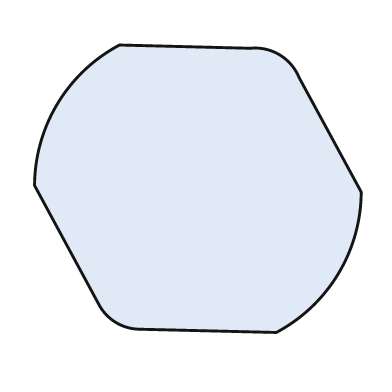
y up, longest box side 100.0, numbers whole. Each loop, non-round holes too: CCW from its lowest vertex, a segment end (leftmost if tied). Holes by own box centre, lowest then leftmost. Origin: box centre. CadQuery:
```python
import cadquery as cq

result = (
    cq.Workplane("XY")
    .moveTo(24.0, -44.0)
    .threePointArc((43.0, -26.0), (50.0, -1.0))
    .lineTo(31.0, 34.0)
    .threePointArc((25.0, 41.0), (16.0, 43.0))
    .lineTo(-24.0, 44.0)
    .threePointArc((-43.0, 26.0), (-50.0, 1.0))
    .lineTo(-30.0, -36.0)
    .threePointArc((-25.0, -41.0), (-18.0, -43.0))
    .close()
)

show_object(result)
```